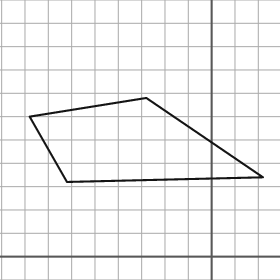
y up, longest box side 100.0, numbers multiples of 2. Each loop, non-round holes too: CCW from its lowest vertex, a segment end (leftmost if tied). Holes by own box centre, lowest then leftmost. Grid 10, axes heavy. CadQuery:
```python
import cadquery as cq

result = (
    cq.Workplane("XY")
    .moveTo(-62.0, 32.0)
    .lineTo(22.0, 34.0)
    .lineTo(-28.0, 68.0)
    .lineTo(-78.0, 60.0)
    .close()
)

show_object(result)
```